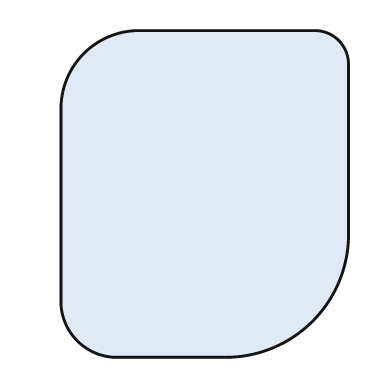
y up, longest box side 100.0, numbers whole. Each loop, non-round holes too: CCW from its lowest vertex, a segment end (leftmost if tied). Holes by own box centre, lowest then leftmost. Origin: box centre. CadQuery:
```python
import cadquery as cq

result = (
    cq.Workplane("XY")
    .moveTo(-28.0, -50.0)
    .lineTo(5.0, -50.0)
    .threePointArc((33.0, -39.0), (44.0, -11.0))
    .lineTo(44.0, 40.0)
    .threePointArc((41.0, 47.0), (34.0, 50.0))
    .lineTo(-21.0, 50.0)
    .threePointArc((-37.0, 43.0), (-44.0, 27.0))
    .lineTo(-44.0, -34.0)
    .threePointArc((-39.0, -45.0), (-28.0, -50.0))
    .close()
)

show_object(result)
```